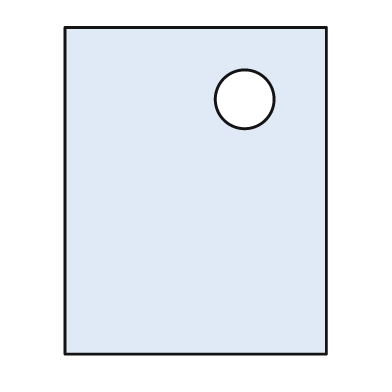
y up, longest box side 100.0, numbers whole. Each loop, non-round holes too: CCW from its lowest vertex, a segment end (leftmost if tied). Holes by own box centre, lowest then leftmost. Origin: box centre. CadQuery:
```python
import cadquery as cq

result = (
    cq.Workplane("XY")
    .moveTo(-40.0, -50.0)
    .lineTo(40.0, -50.0)
    .lineTo(40.0, 50.0)
    .lineTo(-40.0, 50.0)
    .close()
    .moveTo(15.0, 28.0)
    .circle(9.0)
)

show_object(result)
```